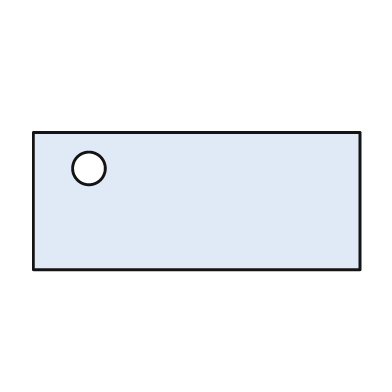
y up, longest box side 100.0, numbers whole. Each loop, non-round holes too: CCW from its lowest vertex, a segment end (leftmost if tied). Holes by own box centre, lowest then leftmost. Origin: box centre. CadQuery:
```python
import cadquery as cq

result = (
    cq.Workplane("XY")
    .moveTo(-50.0, -21.0)
    .lineTo(50.0, -21.0)
    .lineTo(50.0, 21.0)
    .lineTo(-50.0, 21.0)
    .close()
    .moveTo(-33.0, 10.0)
    .circle(5.0)
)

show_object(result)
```